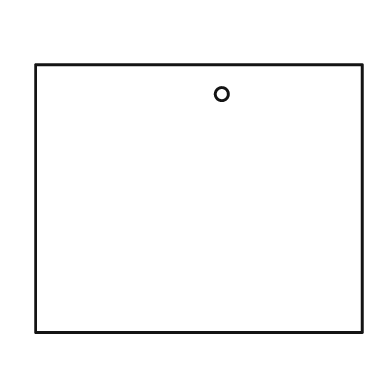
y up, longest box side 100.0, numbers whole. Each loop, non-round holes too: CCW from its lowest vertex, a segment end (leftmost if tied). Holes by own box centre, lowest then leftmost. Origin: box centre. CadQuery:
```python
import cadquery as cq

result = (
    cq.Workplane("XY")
    .moveTo(-50.0, -41.0)
    .lineTo(50.0, -41.0)
    .lineTo(50.0, 41.0)
    .lineTo(-50.0, 41.0)
    .close()
    .moveTo(7.0, 32.0)
    .circle(2.0)
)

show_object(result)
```